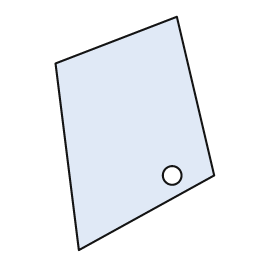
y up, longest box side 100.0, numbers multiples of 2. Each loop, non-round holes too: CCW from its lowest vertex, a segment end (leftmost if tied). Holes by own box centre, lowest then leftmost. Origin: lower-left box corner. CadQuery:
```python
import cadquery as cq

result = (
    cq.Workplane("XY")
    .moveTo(10.0, 0.0)
    .lineTo(68.0, 32.0)
    .lineTo(52.0, 100.0)
    .lineTo(0.0, 80.0)
    .close()
    .moveTo(50.0, 32.0)
    .circle(4.0)
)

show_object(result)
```